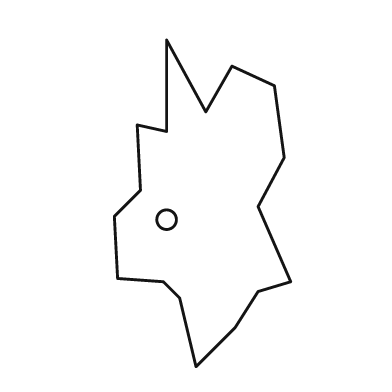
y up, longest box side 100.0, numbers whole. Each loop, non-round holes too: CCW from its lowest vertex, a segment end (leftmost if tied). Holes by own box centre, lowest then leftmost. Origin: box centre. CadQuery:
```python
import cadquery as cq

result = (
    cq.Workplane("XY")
    .moveTo(-2.0, -50.0)
    .lineTo(10.0, -38.0)
    .lineTo(17.0, -27.0)
    .lineTo(27.0, -24.0)
    .lineTo(17.0, -1.0)
    .lineTo(25.0, 14.0)
    .lineTo(22.0, 36.0)
    .lineTo(9.0, 42.0)
    .lineTo(1.0, 28.0)
    .lineTo(-11.0, 50.0)
    .lineTo(-11.0, 22.0)
    .lineTo(-20.0, 24.0)
    .lineTo(-19.0, 4.0)
    .lineTo(-27.0, -4.0)
    .lineTo(-26.0, -23.0)
    .lineTo(-12.0, -24.0)
    .lineTo(-7.0, -29.0)
    .close()
    .moveTo(-11.0, -5.0)
    .circle(3.0)
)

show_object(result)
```